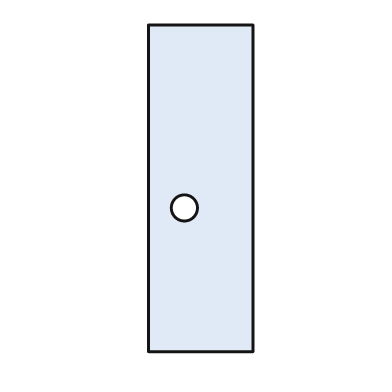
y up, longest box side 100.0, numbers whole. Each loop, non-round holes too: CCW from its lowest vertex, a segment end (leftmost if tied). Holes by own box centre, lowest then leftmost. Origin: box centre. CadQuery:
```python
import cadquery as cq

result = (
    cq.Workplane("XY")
    .moveTo(-16.0, -50.0)
    .lineTo(16.0, -50.0)
    .lineTo(16.0, 50.0)
    .lineTo(-16.0, 50.0)
    .close()
    .moveTo(-5.0, -6.0)
    .circle(4.0)
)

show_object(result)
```